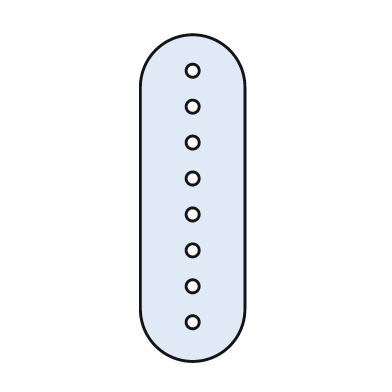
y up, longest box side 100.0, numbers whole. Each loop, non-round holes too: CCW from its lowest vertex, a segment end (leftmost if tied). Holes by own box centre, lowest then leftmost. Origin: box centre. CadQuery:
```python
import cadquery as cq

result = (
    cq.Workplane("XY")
    .moveTo(-16.0, -34.0)
    .threePointArc((0.0, -50.0), (16.0, -34.0))
    .lineTo(16.0, 34.0)
    .threePointArc((0.0, 50.0), (-16.0, 34.0))
    .close()
    .moveTo(0.0, -38.0)
    .circle(2.0)
    .moveTo(0.0, -27.0)
    .circle(2.0)
    .moveTo(0.0, -16.0)
    .circle(2.0)
    .moveTo(0.0, -5.0)
    .circle(2.0)
    .moveTo(0.0, 6.0)
    .circle(2.0)
    .moveTo(0.0, 17.0)
    .circle(2.0)
    .moveTo(0.0, 28.0)
    .circle(2.0)
    .moveTo(0.0, 39.0)
    .circle(2.0)
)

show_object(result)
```